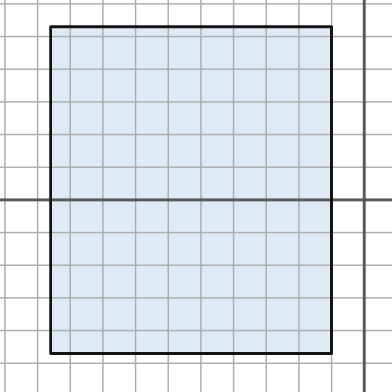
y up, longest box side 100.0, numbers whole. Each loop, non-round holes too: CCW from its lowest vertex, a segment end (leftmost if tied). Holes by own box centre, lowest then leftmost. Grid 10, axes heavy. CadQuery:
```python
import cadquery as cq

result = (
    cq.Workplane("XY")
    .moveTo(-96.0, -47.0)
    .lineTo(-10.0, -47.0)
    .lineTo(-10.0, 53.0)
    .lineTo(-96.0, 53.0)
    .close()
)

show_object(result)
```